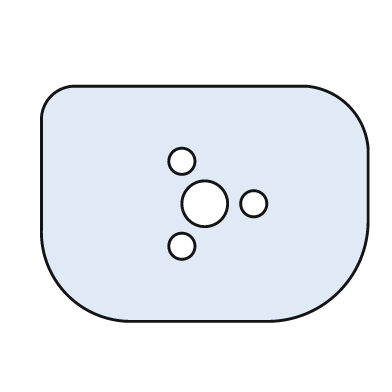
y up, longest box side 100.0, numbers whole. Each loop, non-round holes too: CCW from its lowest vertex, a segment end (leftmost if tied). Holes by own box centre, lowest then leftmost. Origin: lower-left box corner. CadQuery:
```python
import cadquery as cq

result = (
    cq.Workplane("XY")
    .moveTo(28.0, 0.0)
    .lineTo(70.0, 0.0)
    .threePointArc((91.0, 9.0), (100.0, 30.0))
    .lineTo(100.0, 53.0)
    .threePointArc((94.0, 66.0), (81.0, 72.0))
    .lineTo(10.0, 72.0)
    .threePointArc((3.0, 69.0), (0.0, 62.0))
    .lineTo(0.0, 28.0)
    .threePointArc((8.0, 8.0), (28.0, 0.0))
    .close()
    .moveTo(43.0, 23.0)
    .circle(4.0)
    .moveTo(50.0, 36.0)
    .circle(7.0)
    .moveTo(65.0, 36.0)
    .circle(4.0)
    .moveTo(43.0, 49.0)
    .circle(4.0)
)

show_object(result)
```